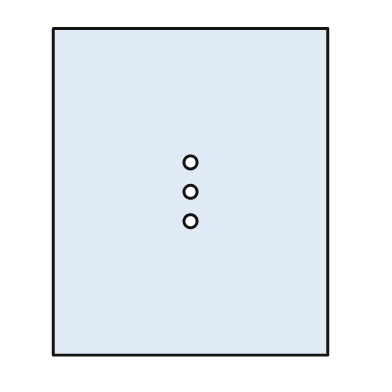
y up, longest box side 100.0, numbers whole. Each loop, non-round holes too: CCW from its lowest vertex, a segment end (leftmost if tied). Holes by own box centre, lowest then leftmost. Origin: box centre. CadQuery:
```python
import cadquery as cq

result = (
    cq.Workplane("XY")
    .moveTo(-42.0, -50.0)
    .lineTo(42.0, -50.0)
    .lineTo(42.0, 50.0)
    .lineTo(-42.0, 50.0)
    .close()
    .moveTo(0.0, -9.0)
    .circle(2.0)
    .moveTo(0.0, 0.0)
    .circle(2.0)
    .moveTo(0.0, 9.0)
    .circle(2.0)
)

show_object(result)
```